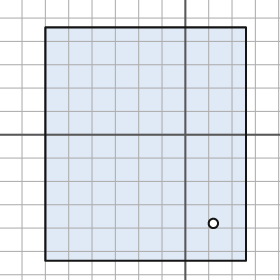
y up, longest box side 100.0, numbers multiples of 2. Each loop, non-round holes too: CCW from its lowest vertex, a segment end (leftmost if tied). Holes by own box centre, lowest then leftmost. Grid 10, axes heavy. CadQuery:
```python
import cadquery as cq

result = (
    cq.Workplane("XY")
    .moveTo(-60.0, -54.0)
    .lineTo(26.0, -54.0)
    .lineTo(26.0, 46.0)
    .lineTo(-60.0, 46.0)
    .close()
    .moveTo(12.0, -38.0)
    .circle(2.0)
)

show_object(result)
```